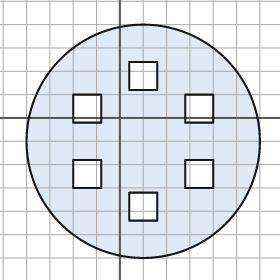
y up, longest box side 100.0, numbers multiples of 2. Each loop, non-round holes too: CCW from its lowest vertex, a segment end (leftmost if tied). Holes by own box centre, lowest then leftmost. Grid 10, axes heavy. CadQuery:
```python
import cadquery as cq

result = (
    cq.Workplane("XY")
    .moveTo(10.0, -10.0)
    .circle(50.0)
    .moveTo(4.0, -44.0)
    .lineTo(16.0, -44.0)
    .lineTo(16.0, -32.0)
    .lineTo(4.0, -32.0)
    .close()
    .moveTo(-20.0, -30.0)
    .lineTo(-8.0, -30.0)
    .lineTo(-8.0, -18.0)
    .lineTo(-20.0, -18.0)
    .close()
    .moveTo(28.0, -30.0)
    .lineTo(40.0, -30.0)
    .lineTo(40.0, -18.0)
    .lineTo(28.0, -18.0)
    .close()
    .moveTo(-20.0, -2.0)
    .lineTo(-8.0, -2.0)
    .lineTo(-8.0, 10.0)
    .lineTo(-20.0, 10.0)
    .close()
    .moveTo(28.0, -2.0)
    .lineTo(40.0, -2.0)
    .lineTo(40.0, 10.0)
    .lineTo(28.0, 10.0)
    .close()
    .moveTo(4.0, 12.0)
    .lineTo(16.0, 12.0)
    .lineTo(16.0, 24.0)
    .lineTo(4.0, 24.0)
    .close()
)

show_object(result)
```